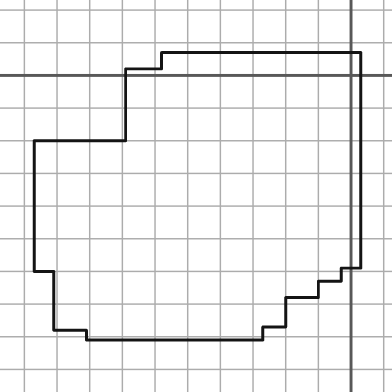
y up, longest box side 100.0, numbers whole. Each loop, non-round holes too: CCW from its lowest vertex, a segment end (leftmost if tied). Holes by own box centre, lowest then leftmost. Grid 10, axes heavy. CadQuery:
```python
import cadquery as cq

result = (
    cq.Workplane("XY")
    .moveTo(-81.0, -81.0)
    .lineTo(-27.0, -81.0)
    .lineTo(-27.0, -77.0)
    .lineTo(-20.0, -77.0)
    .lineTo(-20.0, -68.0)
    .lineTo(-10.0, -68.0)
    .lineTo(-10.0, -63.0)
    .lineTo(-3.0, -63.0)
    .lineTo(-3.0, -59.0)
    .lineTo(3.0, -59.0)
    .lineTo(3.0, 7.0)
    .lineTo(-58.0, 7.0)
    .lineTo(-58.0, 2.0)
    .lineTo(-69.0, 2.0)
    .lineTo(-69.0, -20.0)
    .lineTo(-97.0, -20.0)
    .lineTo(-97.0, -60.0)
    .lineTo(-91.0, -60.0)
    .lineTo(-91.0, -78.0)
    .lineTo(-81.0, -78.0)
    .close()
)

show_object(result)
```